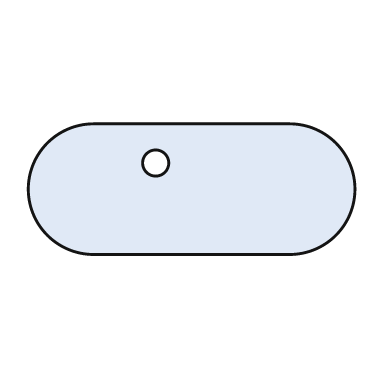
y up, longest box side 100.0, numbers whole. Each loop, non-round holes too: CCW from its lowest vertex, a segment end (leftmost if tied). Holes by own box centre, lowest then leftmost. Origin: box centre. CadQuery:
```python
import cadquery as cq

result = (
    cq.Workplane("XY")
    .moveTo(-30.0, -20.0)
    .lineTo(30.0, -20.0)
    .threePointArc((50.0, 0.0), (30.0, 20.0))
    .lineTo(-30.0, 20.0)
    .threePointArc((-50.0, 0.0), (-30.0, -20.0))
    .close()
    .moveTo(-11.0, 8.0)
    .circle(4.0)
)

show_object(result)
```